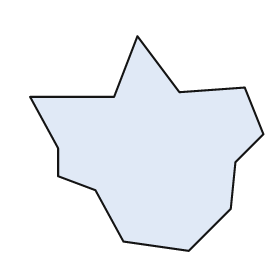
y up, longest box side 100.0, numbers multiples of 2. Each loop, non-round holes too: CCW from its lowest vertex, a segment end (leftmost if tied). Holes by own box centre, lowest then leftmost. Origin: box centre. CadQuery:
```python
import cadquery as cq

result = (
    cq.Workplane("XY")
    .moveTo(18.0, -46.0)
    .lineTo(36.0, -28.0)
    .lineTo(38.0, -8.0)
    .lineTo(50.0, 4.0)
    .lineTo(42.0, 24.0)
    .lineTo(14.0, 22.0)
    .lineTo(-4.0, 46.0)
    .lineTo(-14.0, 20.0)
    .lineTo(-50.0, 20.0)
    .lineTo(-38.0, -2.0)
    .lineTo(-38.0, -14.0)
    .lineTo(-22.0, -20.0)
    .lineTo(-10.0, -42.0)
    .close()
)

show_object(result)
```